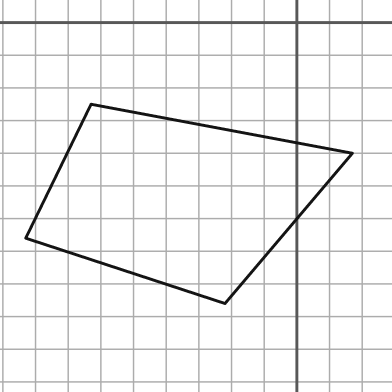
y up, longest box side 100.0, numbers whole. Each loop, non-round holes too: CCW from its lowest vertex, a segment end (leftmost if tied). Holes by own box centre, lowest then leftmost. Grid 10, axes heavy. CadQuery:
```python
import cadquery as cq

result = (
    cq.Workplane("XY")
    .moveTo(-22.0, -86.0)
    .lineTo(17.0, -40.0)
    .lineTo(-63.0, -25.0)
    .lineTo(-83.0, -66.0)
    .close()
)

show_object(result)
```